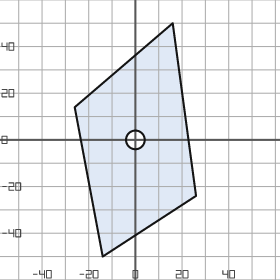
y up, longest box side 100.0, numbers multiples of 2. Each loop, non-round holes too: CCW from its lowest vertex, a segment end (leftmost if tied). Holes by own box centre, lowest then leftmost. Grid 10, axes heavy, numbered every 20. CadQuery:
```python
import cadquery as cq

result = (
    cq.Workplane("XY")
    .moveTo(-14.0, -50.0)
    .lineTo(26.0, -24.0)
    .lineTo(16.0, 50.0)
    .lineTo(-26.0, 14.0)
    .close()
    .moveTo(0.0, 0.0)
    .circle(4.0)
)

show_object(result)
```